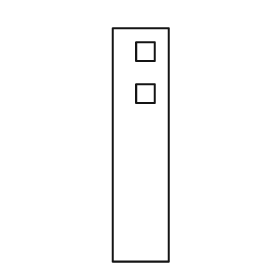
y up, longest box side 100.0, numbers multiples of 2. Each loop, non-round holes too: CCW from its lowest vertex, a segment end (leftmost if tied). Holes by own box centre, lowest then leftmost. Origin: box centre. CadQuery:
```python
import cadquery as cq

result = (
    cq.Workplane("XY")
    .moveTo(-12.0, -50.0)
    .lineTo(12.0, -50.0)
    .lineTo(12.0, 50.0)
    .lineTo(-12.0, 50.0)
    .close()
    .moveTo(-2.0, 18.0)
    .lineTo(6.0, 18.0)
    .lineTo(6.0, 26.0)
    .lineTo(-2.0, 26.0)
    .close()
    .moveTo(-2.0, 36.0)
    .lineTo(6.0, 36.0)
    .lineTo(6.0, 44.0)
    .lineTo(-2.0, 44.0)
    .close()
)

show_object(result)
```